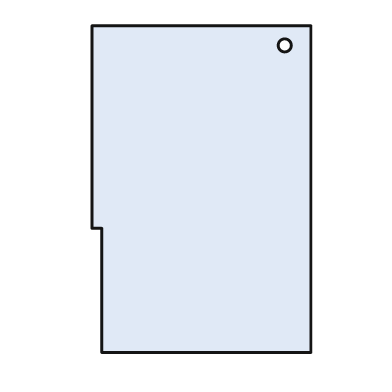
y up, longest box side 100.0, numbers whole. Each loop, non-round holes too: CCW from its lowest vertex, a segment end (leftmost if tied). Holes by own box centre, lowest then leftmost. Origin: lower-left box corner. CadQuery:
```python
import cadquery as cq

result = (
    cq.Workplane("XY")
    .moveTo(3.0, 0.0)
    .lineTo(67.0, 0.0)
    .lineTo(67.0, 100.0)
    .lineTo(0.0, 100.0)
    .lineTo(0.0, 38.0)
    .lineTo(3.0, 38.0)
    .close()
    .moveTo(59.0, 94.0)
    .circle(2.0)
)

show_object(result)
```